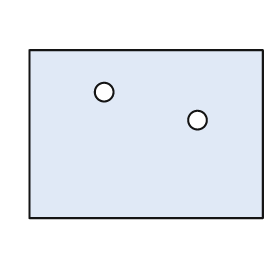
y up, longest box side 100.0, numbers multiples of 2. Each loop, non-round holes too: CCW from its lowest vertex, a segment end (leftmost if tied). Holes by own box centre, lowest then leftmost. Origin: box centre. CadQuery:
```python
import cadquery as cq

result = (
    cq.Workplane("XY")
    .moveTo(-50.0, -36.0)
    .lineTo(50.0, -36.0)
    .lineTo(50.0, 36.0)
    .lineTo(-50.0, 36.0)
    .close()
    .moveTo(22.0, 6.0)
    .circle(4.0)
    .moveTo(-18.0, 18.0)
    .circle(4.0)
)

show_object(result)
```